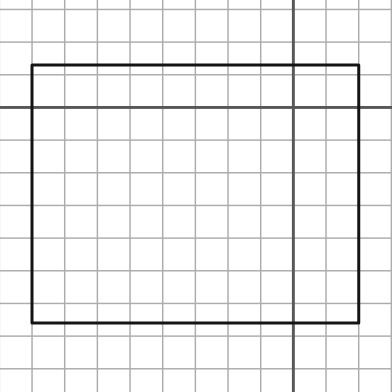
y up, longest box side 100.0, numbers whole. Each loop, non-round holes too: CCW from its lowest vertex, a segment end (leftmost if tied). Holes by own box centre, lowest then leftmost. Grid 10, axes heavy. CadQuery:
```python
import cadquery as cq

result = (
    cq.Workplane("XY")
    .moveTo(-80.0, -66.0)
    .lineTo(20.0, -66.0)
    .lineTo(20.0, 13.0)
    .lineTo(-80.0, 13.0)
    .close()
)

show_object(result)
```